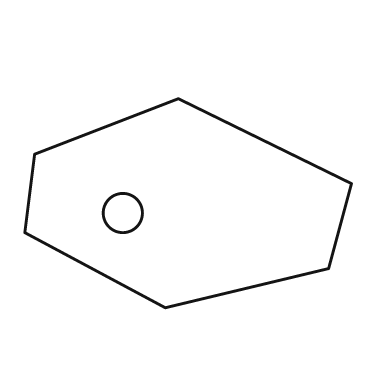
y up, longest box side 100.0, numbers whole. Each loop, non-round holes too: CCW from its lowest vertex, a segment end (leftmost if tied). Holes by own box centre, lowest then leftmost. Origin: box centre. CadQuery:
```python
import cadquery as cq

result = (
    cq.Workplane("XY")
    .moveTo(-7.0, -32.0)
    .lineTo(43.0, -20.0)
    .lineTo(50.0, 6.0)
    .lineTo(-3.0, 32.0)
    .lineTo(-47.0, 15.0)
    .lineTo(-50.0, -9.0)
    .close()
    .moveTo(-20.0, -3.0)
    .circle(6.0)
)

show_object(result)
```